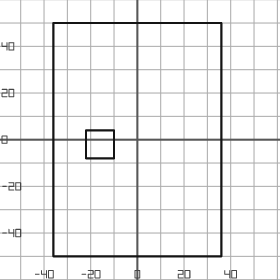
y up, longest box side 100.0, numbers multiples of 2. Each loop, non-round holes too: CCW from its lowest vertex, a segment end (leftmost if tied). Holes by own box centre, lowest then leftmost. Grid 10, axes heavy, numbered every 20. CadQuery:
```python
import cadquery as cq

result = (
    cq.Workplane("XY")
    .moveTo(-36.0, -50.0)
    .lineTo(36.0, -50.0)
    .lineTo(36.0, 50.0)
    .lineTo(-36.0, 50.0)
    .close()
    .moveTo(-22.0, -8.0)
    .lineTo(-10.0, -8.0)
    .lineTo(-10.0, 4.0)
    .lineTo(-22.0, 4.0)
    .close()
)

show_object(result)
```